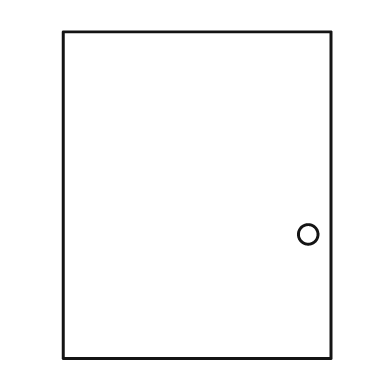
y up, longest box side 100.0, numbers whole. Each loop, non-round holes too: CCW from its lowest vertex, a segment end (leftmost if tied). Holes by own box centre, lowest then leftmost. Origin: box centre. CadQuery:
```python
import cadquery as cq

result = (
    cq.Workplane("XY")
    .moveTo(-41.0, -50.0)
    .lineTo(41.0, -50.0)
    .lineTo(41.0, 50.0)
    .lineTo(-41.0, 50.0)
    .close()
    .moveTo(34.0, -12.0)
    .circle(3.0)
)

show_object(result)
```